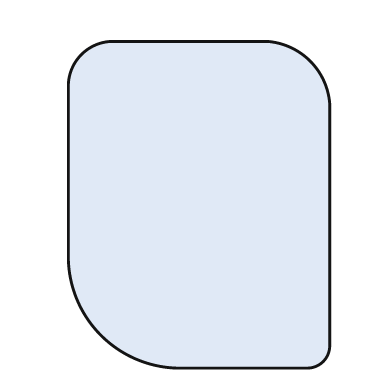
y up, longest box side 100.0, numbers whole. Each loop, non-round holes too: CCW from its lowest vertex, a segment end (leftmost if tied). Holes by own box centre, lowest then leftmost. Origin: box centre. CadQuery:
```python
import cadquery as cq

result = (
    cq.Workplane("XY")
    .moveTo(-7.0, -50.0)
    .lineTo(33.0, -50.0)
    .threePointArc((38.0, -48.0), (40.0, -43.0))
    .lineTo(40.0, 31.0)
    .threePointArc((34.0, 44.0), (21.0, 50.0))
    .lineTo(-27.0, 50.0)
    .threePointArc((-36.0, 46.0), (-40.0, 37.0))
    .lineTo(-40.0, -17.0)
    .threePointArc((-30.0, -40.0), (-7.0, -50.0))
    .close()
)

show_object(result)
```